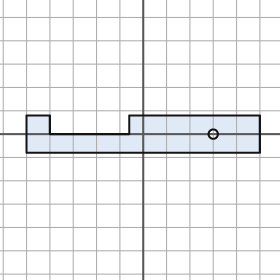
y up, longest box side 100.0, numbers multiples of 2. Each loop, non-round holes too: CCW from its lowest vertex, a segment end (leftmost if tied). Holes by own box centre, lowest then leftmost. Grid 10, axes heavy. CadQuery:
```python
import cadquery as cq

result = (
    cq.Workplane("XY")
    .moveTo(-50.0, -8.0)
    .lineTo(50.0, -8.0)
    .lineTo(50.0, 8.0)
    .lineTo(-6.0, 8.0)
    .lineTo(-6.0, 0.0)
    .lineTo(-40.0, 0.0)
    .lineTo(-40.0, 8.0)
    .lineTo(-50.0, 8.0)
    .close()
    .moveTo(30.0, 0.0)
    .circle(2.0)
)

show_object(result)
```